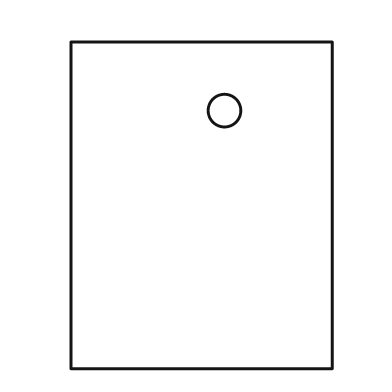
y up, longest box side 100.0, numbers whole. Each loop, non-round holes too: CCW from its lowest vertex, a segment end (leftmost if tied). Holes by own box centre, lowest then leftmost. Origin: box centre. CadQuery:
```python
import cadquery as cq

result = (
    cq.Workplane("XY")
    .moveTo(-40.0, -50.0)
    .lineTo(40.0, -50.0)
    .lineTo(40.0, 50.0)
    .lineTo(-40.0, 50.0)
    .close()
    .moveTo(7.0, 29.0)
    .circle(5.0)
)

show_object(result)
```